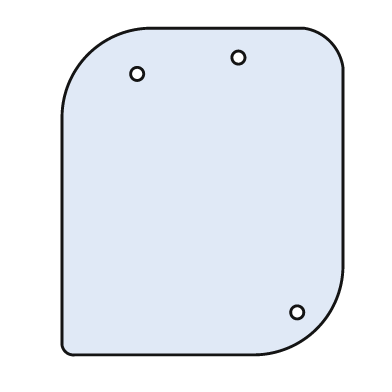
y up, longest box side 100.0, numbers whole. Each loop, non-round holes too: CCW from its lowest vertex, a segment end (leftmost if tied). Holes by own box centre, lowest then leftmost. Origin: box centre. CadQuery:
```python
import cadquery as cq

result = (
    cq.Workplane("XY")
    .moveTo(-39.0, -50.0)
    .lineTo(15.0, -50.0)
    .threePointArc((35.0, -42.0), (43.0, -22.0))
    .lineTo(43.0, 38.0)
    .threePointArc((39.0, 46.0), (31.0, 50.0))
    .lineTo(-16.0, 50.0)
    .threePointArc((-35.0, 42.0), (-43.0, 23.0))
    .lineTo(-43.0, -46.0)
    .threePointArc((-42.0, -49.0), (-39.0, -50.0))
    .close()
    .moveTo(29.0, -37.0)
    .circle(2.0)
    .moveTo(-20.0, 36.0)
    .circle(2.0)
    .moveTo(11.0, 41.0)
    .circle(2.0)
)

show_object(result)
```